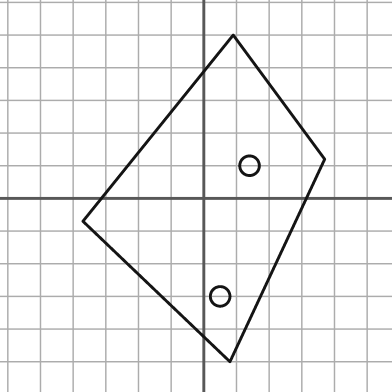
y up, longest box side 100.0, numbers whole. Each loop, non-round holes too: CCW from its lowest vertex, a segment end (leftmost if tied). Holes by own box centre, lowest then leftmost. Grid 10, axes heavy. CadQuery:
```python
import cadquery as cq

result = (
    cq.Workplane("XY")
    .moveTo(8.0, -50.0)
    .lineTo(37.0, 12.0)
    .lineTo(9.0, 50.0)
    .lineTo(-37.0, -7.0)
    .close()
    .moveTo(5.0, -30.0)
    .circle(3.0)
    .moveTo(14.0, 10.0)
    .circle(3.0)
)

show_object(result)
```